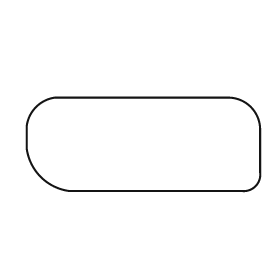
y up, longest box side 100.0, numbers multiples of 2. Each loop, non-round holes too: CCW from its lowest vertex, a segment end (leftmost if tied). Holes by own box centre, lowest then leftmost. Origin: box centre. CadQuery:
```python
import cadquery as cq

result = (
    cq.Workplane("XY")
    .moveTo(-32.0, -20.0)
    .lineTo(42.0, -20.0)
    .threePointArc((48.0, -18.0), (50.0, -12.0))
    .lineTo(50.0, 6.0)
    .threePointArc((46.0, 16.0), (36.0, 20.0))
    .lineTo(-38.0, 20.0)
    .threePointArc((-46.0, 16.0), (-50.0, 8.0))
    .lineTo(-50.0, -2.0)
    .threePointArc((-44.0, -14.0), (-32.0, -20.0))
    .close()
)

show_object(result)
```